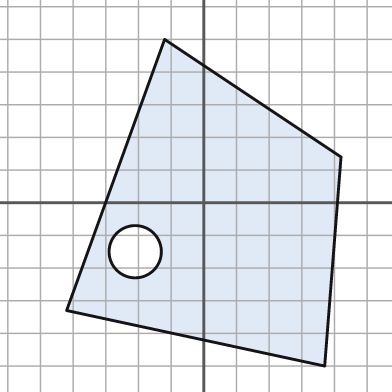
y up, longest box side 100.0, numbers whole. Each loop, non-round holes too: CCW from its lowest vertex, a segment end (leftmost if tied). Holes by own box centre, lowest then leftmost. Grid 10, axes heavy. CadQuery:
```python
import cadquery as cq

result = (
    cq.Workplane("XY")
    .moveTo(37.0, -50.0)
    .lineTo(42.0, 14.0)
    .lineTo(-12.0, 50.0)
    .lineTo(-42.0, -33.0)
    .close()
    .moveTo(-21.0, -15.0)
    .circle(8.0)
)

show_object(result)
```